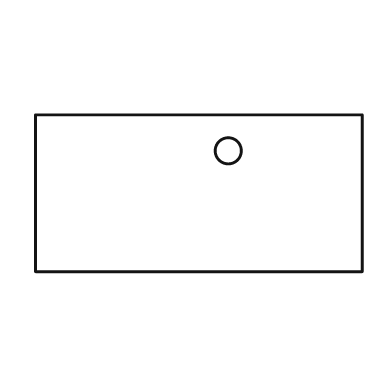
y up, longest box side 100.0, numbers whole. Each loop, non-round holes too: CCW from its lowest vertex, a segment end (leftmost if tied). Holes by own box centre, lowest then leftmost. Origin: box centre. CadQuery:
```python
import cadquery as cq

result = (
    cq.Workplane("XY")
    .moveTo(-50.0, -24.0)
    .lineTo(50.0, -24.0)
    .lineTo(50.0, 24.0)
    .lineTo(-50.0, 24.0)
    .close()
    .moveTo(9.0, 13.0)
    .circle(4.0)
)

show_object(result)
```